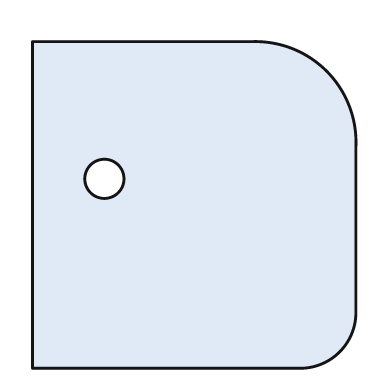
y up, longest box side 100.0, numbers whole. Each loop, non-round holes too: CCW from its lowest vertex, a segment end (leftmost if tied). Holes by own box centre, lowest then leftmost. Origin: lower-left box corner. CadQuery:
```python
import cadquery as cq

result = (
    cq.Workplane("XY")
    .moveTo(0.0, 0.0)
    .lineTo(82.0, 0.0)
    .threePointArc((94.0, 5.0), (99.0, 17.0))
    .lineTo(99.0, 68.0)
    .threePointArc((90.0, 91.0), (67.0, 100.0))
    .lineTo(0.0, 100.0)
    .close()
    .moveTo(22.0, 58.0)
    .circle(6.0)
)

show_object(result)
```